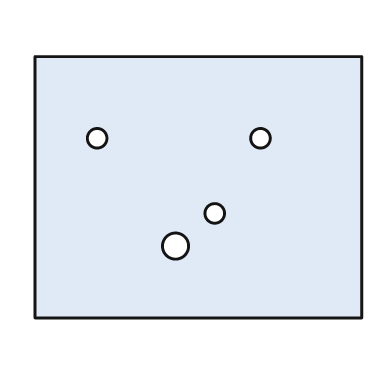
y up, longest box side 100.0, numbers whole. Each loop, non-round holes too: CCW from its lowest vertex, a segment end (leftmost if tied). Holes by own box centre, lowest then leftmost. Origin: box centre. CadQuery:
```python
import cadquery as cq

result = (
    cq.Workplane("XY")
    .moveTo(-50.0, -40.0)
    .lineTo(50.0, -40.0)
    .lineTo(50.0, 40.0)
    .lineTo(-50.0, 40.0)
    .close()
    .moveTo(-7.0, -18.0)
    .circle(4.0)
    .moveTo(5.0, -8.0)
    .circle(3.0)
    .moveTo(-31.0, 15.0)
    .circle(3.0)
    .moveTo(19.0, 15.0)
    .circle(3.0)
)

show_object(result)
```